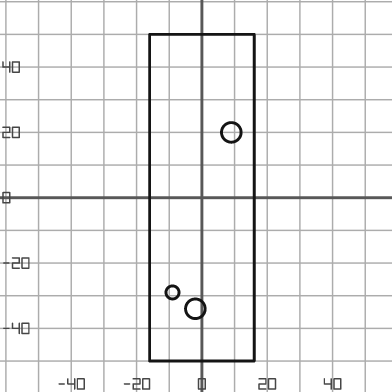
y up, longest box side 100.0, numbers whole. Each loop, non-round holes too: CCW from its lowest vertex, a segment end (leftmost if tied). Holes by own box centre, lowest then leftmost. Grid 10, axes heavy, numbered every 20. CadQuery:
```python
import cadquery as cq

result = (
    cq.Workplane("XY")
    .moveTo(-16.0, -50.0)
    .lineTo(16.0, -50.0)
    .lineTo(16.0, 50.0)
    .lineTo(-16.0, 50.0)
    .close()
    .moveTo(-2.0, -34.0)
    .circle(3.0)
    .moveTo(-9.0, -29.0)
    .circle(2.0)
    .moveTo(9.0, 20.0)
    .circle(3.0)
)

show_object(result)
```